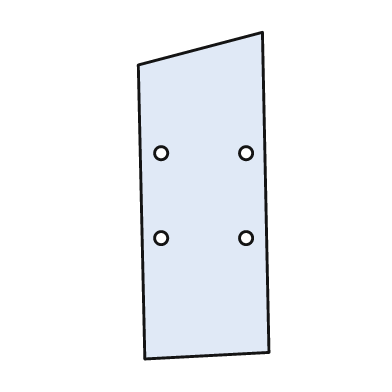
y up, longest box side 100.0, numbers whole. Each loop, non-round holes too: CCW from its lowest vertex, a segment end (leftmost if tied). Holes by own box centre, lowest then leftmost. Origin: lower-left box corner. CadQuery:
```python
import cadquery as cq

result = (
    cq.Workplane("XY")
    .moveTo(2.0, 0.0)
    .lineTo(40.0, 2.0)
    .lineTo(38.0, 100.0)
    .lineTo(0.0, 90.0)
    .close()
    .moveTo(7.0, 37.0)
    .circle(2.0)
    .moveTo(33.0, 37.0)
    .circle(2.0)
    .moveTo(7.0, 63.0)
    .circle(2.0)
    .moveTo(33.0, 63.0)
    .circle(2.0)
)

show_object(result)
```